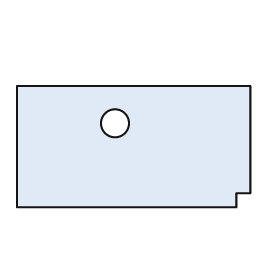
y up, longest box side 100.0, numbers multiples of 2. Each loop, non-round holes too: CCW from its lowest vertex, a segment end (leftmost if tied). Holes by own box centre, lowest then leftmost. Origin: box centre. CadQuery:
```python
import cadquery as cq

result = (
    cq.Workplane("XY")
    .moveTo(-50.0, -26.0)
    .lineTo(44.0, -26.0)
    .lineTo(44.0, -20.0)
    .lineTo(50.0, -20.0)
    .lineTo(50.0, 26.0)
    .lineTo(-50.0, 26.0)
    .close()
    .moveTo(-8.0, 10.0)
    .circle(6.0)
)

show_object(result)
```